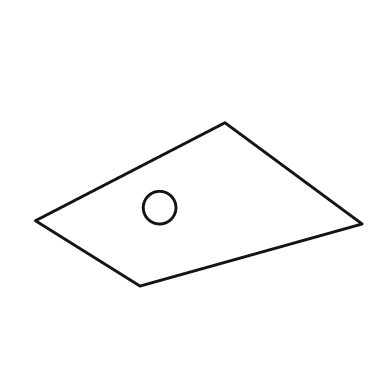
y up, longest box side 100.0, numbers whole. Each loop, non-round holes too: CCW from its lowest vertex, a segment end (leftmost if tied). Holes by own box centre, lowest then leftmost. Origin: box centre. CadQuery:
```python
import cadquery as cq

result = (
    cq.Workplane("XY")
    .moveTo(-18.0, -25.0)
    .lineTo(50.0, -6.0)
    .lineTo(8.0, 25.0)
    .lineTo(-50.0, -5.0)
    .close()
    .moveTo(-12.0, -1.0)
    .circle(5.0)
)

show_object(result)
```